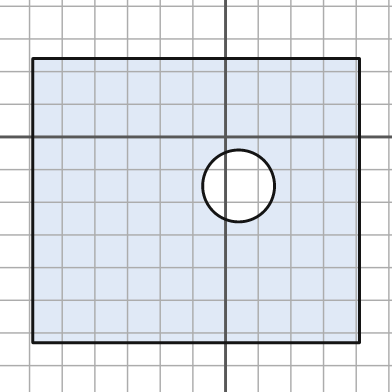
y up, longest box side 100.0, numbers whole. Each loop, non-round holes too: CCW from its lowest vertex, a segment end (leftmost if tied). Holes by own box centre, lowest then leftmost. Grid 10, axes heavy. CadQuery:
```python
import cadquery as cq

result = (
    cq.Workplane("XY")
    .moveTo(-59.0, -63.0)
    .lineTo(41.0, -63.0)
    .lineTo(41.0, 24.0)
    .lineTo(-59.0, 24.0)
    .close()
    .moveTo(4.0, -15.0)
    .circle(11.0)
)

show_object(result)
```